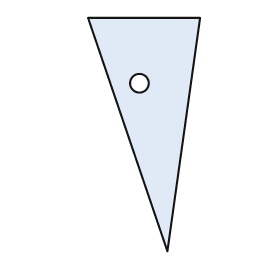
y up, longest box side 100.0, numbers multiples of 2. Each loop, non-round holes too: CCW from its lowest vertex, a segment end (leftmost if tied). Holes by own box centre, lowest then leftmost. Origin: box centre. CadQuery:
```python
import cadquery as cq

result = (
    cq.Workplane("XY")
    .moveTo(10.0, -50.0)
    .lineTo(24.0, 50.0)
    .lineTo(-24.0, 50.0)
    .close()
    .moveTo(-2.0, 22.0)
    .circle(4.0)
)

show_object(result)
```